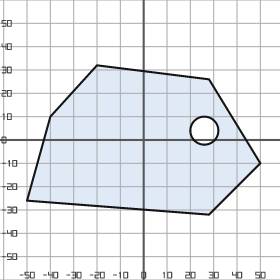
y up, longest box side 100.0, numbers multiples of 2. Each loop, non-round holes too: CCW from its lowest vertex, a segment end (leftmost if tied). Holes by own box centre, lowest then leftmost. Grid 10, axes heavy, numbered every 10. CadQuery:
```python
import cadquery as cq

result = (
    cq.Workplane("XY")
    .moveTo(28.0, -32.0)
    .lineTo(50.0, -10.0)
    .lineTo(28.0, 26.0)
    .lineTo(-20.0, 32.0)
    .lineTo(-40.0, 10.0)
    .lineTo(-50.0, -26.0)
    .close()
    .moveTo(26.0, 4.0)
    .circle(6.0)
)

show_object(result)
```